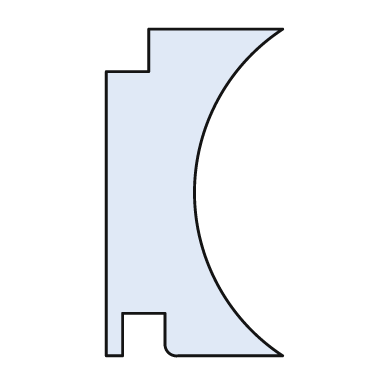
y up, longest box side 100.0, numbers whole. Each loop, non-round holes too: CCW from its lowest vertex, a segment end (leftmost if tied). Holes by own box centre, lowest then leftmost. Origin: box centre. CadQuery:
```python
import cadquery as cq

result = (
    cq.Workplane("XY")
    .moveTo(-27.0, -50.0)
    .lineTo(-22.0, -50.0)
    .lineTo(-22.0, -37.0)
    .lineTo(-9.0, -37.0)
    .lineTo(-9.0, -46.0)
    .threePointArc((-8.0, -49.0), (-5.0, -50.0))
    .lineTo(27.0, -50.0)
    .threePointArc((0.0, 0.0), (27.0, 50.0))
    .lineTo(-14.0, 50.0)
    .lineTo(-14.0, 37.0)
    .lineTo(-27.0, 37.0)
    .close()
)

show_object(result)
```